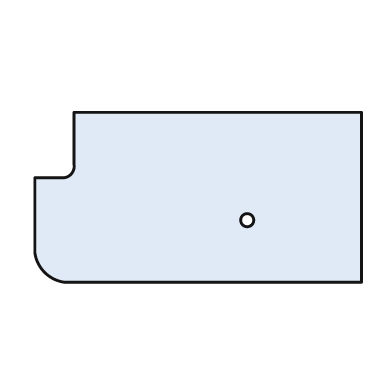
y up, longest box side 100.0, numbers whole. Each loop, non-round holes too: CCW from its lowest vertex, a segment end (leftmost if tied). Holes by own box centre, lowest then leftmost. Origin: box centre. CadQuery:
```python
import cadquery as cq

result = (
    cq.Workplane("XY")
    .moveTo(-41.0, -26.0)
    .lineTo(50.0, -26.0)
    .lineTo(50.0, 26.0)
    .lineTo(-38.0, 26.0)
    .lineTo(-38.0, 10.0)
    .threePointArc((-39.0, 7.0), (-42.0, 6.0))
    .lineTo(-50.0, 6.0)
    .lineTo(-50.0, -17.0)
    .threePointArc((-47.0, -23.0), (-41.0, -26.0))
    .close()
    .moveTo(15.0, -7.0)
    .circle(2.0)
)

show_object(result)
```